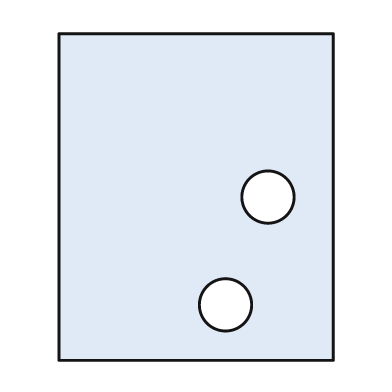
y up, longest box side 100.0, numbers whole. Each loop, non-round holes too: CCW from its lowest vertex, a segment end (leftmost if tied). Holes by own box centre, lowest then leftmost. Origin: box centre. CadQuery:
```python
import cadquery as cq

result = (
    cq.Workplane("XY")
    .moveTo(-42.0, -50.0)
    .lineTo(42.0, -50.0)
    .lineTo(42.0, 50.0)
    .lineTo(-42.0, 50.0)
    .close()
    .moveTo(9.0, -33.0)
    .circle(8.0)
    .moveTo(22.0, 0.0)
    .circle(8.0)
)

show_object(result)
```